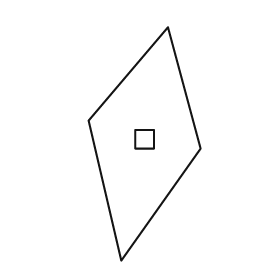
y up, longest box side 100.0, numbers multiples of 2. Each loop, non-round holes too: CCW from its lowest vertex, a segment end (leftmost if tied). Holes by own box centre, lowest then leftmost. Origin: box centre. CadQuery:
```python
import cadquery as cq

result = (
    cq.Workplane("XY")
    .moveTo(-10.0, -50.0)
    .lineTo(24.0, -2.0)
    .lineTo(10.0, 50.0)
    .lineTo(-24.0, 10.0)
    .close()
    .moveTo(-4.0, -2.0)
    .lineTo(4.0, -2.0)
    .lineTo(4.0, 6.0)
    .lineTo(-4.0, 6.0)
    .close()
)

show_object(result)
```